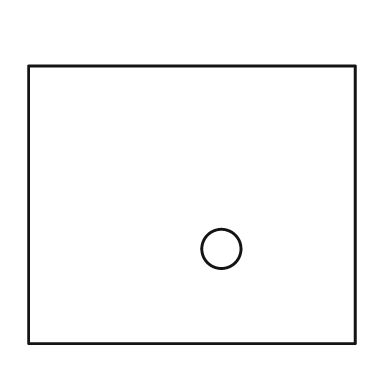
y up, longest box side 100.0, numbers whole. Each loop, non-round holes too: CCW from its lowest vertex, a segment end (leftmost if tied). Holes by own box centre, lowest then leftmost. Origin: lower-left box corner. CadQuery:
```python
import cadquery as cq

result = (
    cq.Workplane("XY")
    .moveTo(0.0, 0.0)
    .lineTo(100.0, 0.0)
    .lineTo(100.0, 85.0)
    .lineTo(0.0, 85.0)
    .close()
    .moveTo(59.0, 29.0)
    .circle(6.0)
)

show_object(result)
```